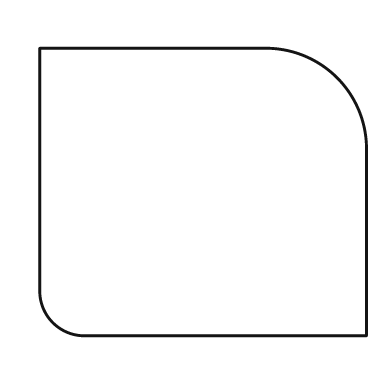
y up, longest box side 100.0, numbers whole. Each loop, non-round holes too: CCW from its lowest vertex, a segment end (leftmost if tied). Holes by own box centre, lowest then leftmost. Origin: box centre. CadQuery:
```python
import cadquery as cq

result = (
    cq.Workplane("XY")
    .moveTo(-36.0, -44.0)
    .lineTo(50.0, -44.0)
    .lineTo(50.0, 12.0)
    .threePointArc((41.0, 35.0), (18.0, 44.0))
    .lineTo(-50.0, 44.0)
    .lineTo(-50.0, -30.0)
    .threePointArc((-46.0, -40.0), (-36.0, -44.0))
    .close()
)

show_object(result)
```